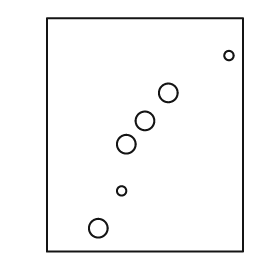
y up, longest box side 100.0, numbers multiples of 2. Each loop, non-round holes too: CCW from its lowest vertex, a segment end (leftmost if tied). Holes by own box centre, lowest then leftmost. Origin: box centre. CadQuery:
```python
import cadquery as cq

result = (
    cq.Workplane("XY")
    .moveTo(-42.0, -50.0)
    .lineTo(42.0, -50.0)
    .lineTo(42.0, 50.0)
    .lineTo(-42.0, 50.0)
    .close()
    .moveTo(-20.0, -40.0)
    .circle(4.0)
    .moveTo(-10.0, -24.0)
    .circle(2.0)
    .moveTo(-8.0, -4.0)
    .circle(4.0)
    .moveTo(0.0, 6.0)
    .circle(4.0)
    .moveTo(10.0, 18.0)
    .circle(4.0)
    .moveTo(36.0, 34.0)
    .circle(2.0)
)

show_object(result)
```